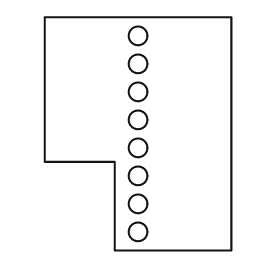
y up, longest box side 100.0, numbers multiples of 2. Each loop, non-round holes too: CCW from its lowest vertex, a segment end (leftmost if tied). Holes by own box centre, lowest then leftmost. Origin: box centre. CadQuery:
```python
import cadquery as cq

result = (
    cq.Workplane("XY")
    .moveTo(-10.0, -50.0)
    .lineTo(40.0, -50.0)
    .lineTo(40.0, 50.0)
    .lineTo(-40.0, 50.0)
    .lineTo(-40.0, -12.0)
    .lineTo(-10.0, -12.0)
    .close()
    .moveTo(0.0, -42.0)
    .circle(4.0)
    .moveTo(0.0, -30.0)
    .circle(4.0)
    .moveTo(0.0, -18.0)
    .circle(4.0)
    .moveTo(0.0, -6.0)
    .circle(4.0)
    .moveTo(0.0, 6.0)
    .circle(4.0)
    .moveTo(0.0, 18.0)
    .circle(4.0)
    .moveTo(0.0, 30.0)
    .circle(4.0)
    .moveTo(0.0, 42.0)
    .circle(4.0)
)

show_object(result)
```